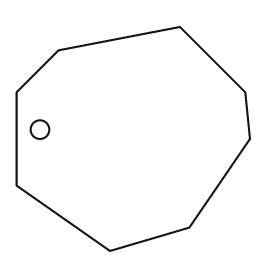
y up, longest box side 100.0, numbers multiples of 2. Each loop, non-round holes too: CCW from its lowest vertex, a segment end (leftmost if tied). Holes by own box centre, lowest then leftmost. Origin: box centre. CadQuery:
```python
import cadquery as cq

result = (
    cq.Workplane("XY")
    .moveTo(-10.0, -48.0)
    .lineTo(24.0, -38.0)
    .lineTo(50.0, 0.0)
    .lineTo(48.0, 20.0)
    .lineTo(20.0, 48.0)
    .lineTo(-32.0, 38.0)
    .lineTo(-50.0, 20.0)
    .lineTo(-50.0, -20.0)
    .close()
    .moveTo(-40.0, 4.0)
    .circle(4.0)
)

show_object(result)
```